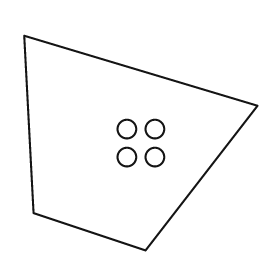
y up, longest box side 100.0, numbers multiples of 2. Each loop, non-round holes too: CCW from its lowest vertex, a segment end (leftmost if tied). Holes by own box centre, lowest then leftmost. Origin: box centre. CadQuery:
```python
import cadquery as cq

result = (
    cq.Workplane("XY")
    .moveTo(2.0, -46.0)
    .lineTo(50.0, 16.0)
    .lineTo(-50.0, 46.0)
    .lineTo(-46.0, -30.0)
    .close()
    .moveTo(-6.0, -6.0)
    .circle(4.0)
    .moveTo(6.0, -6.0)
    .circle(4.0)
    .moveTo(-6.0, 6.0)
    .circle(4.0)
    .moveTo(6.0, 6.0)
    .circle(4.0)
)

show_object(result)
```